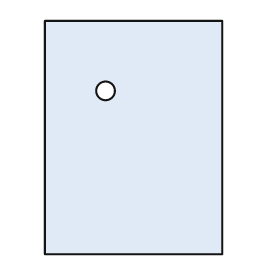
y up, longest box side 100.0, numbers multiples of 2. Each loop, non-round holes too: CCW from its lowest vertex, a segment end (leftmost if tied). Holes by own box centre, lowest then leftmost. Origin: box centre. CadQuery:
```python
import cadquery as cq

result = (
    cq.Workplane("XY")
    .moveTo(-38.0, -50.0)
    .lineTo(38.0, -50.0)
    .lineTo(38.0, 50.0)
    .lineTo(-38.0, 50.0)
    .close()
    .moveTo(-12.0, 20.0)
    .circle(4.0)
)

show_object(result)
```